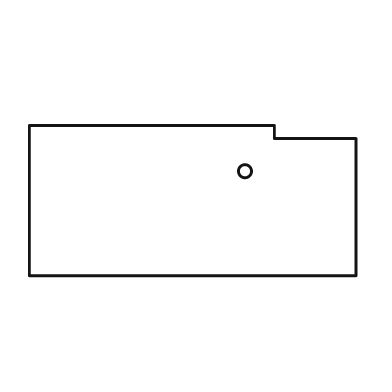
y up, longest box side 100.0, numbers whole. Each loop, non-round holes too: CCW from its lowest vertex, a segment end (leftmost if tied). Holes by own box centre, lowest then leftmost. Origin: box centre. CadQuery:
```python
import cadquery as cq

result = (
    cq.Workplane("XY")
    .moveTo(-50.0, -23.0)
    .lineTo(50.0, -23.0)
    .lineTo(50.0, 19.0)
    .lineTo(25.0, 19.0)
    .lineTo(25.0, 23.0)
    .lineTo(-50.0, 23.0)
    .close()
    .moveTo(16.0, 9.0)
    .circle(2.0)
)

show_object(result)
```